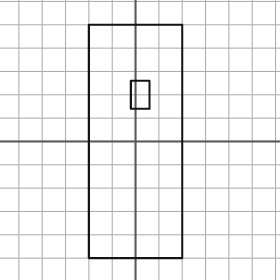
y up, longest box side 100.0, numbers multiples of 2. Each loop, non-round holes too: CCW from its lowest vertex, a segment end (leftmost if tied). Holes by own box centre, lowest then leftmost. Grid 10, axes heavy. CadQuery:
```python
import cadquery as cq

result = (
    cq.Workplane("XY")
    .moveTo(-20.0, -50.0)
    .lineTo(20.0, -50.0)
    .lineTo(20.0, 50.0)
    .lineTo(-20.0, 50.0)
    .close()
    .moveTo(-2.0, 14.0)
    .lineTo(6.0, 14.0)
    .lineTo(6.0, 26.0)
    .lineTo(-2.0, 26.0)
    .close()
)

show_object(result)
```